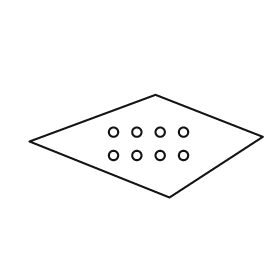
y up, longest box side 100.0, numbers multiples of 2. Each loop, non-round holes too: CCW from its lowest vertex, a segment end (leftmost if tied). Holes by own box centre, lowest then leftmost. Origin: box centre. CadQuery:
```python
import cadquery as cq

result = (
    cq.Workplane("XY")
    .moveTo(10.0, -22.0)
    .lineTo(50.0, 4.0)
    .lineTo(4.0, 22.0)
    .lineTo(-50.0, 2.0)
    .close()
    .moveTo(-14.0, -4.0)
    .circle(2.0)
    .moveTo(-4.0, -4.0)
    .circle(2.0)
    .moveTo(6.0, -4.0)
    .circle(2.0)
    .moveTo(16.0, -4.0)
    .circle(2.0)
    .moveTo(-14.0, 6.0)
    .circle(2.0)
    .moveTo(-4.0, 6.0)
    .circle(2.0)
    .moveTo(6.0, 6.0)
    .circle(2.0)
    .moveTo(16.0, 6.0)
    .circle(2.0)
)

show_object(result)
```